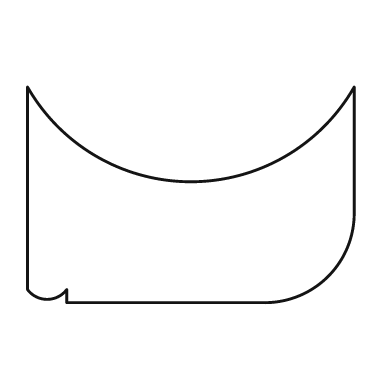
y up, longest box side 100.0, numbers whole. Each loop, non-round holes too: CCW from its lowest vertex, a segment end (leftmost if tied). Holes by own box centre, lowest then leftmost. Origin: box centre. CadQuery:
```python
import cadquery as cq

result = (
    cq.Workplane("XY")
    .moveTo(-38.0, -33.0)
    .lineTo(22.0, -33.0)
    .threePointArc((42.0, -25.0), (50.0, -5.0))
    .lineTo(50.0, 33.0)
    .threePointArc((0.0, 4.0), (-50.0, 33.0))
    .lineTo(-50.0, -29.0)
    .threePointArc((-44.0, -32.0), (-38.0, -29.0))
    .close()
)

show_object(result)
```